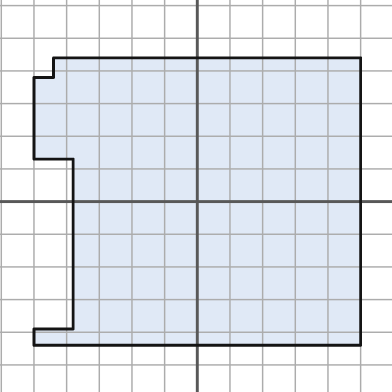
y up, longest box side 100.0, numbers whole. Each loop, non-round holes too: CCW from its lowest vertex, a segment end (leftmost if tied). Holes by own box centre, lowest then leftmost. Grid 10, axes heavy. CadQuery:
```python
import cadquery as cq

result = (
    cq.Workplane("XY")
    .moveTo(-50.0, -44.0)
    .lineTo(50.0, -44.0)
    .lineTo(50.0, 44.0)
    .lineTo(-44.0, 44.0)
    .lineTo(-44.0, 38.0)
    .lineTo(-50.0, 38.0)
    .lineTo(-50.0, 13.0)
    .lineTo(-38.0, 13.0)
    .lineTo(-38.0, -39.0)
    .lineTo(-50.0, -39.0)
    .close()
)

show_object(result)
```